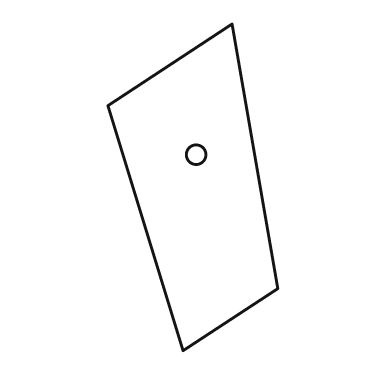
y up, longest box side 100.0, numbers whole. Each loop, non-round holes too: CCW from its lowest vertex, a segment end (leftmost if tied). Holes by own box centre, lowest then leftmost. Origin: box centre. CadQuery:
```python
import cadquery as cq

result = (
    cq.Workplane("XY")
    .moveTo(-3.0, -50.0)
    .lineTo(26.0, -31.0)
    .lineTo(12.0, 50.0)
    .lineTo(-26.0, 25.0)
    .close()
    .moveTo(1.0, 10.0)
    .circle(3.0)
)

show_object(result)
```